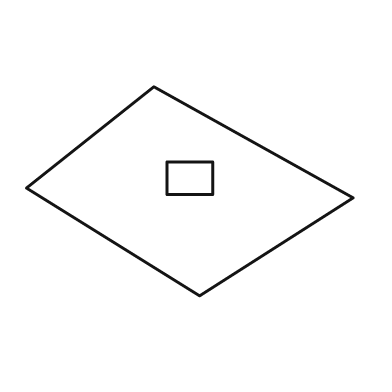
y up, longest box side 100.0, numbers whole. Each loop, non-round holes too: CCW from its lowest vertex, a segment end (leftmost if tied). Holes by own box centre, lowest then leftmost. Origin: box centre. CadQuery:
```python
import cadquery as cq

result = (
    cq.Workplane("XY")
    .moveTo(3.0, -32.0)
    .lineTo(50.0, -2.0)
    .lineTo(-11.0, 32.0)
    .lineTo(-50.0, 1.0)
    .close()
    .moveTo(-7.0, -1.0)
    .lineTo(7.0, -1.0)
    .lineTo(7.0, 9.0)
    .lineTo(-7.0, 9.0)
    .close()
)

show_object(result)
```